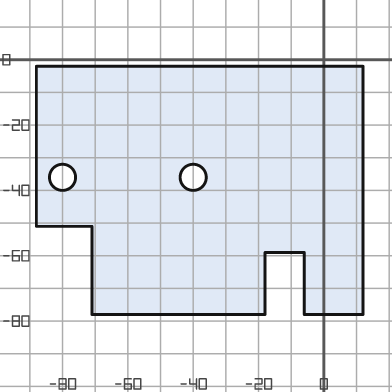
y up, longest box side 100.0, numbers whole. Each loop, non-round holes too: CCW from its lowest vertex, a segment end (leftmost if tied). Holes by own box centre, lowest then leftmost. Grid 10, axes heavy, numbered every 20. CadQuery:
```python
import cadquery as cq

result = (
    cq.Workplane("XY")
    .moveTo(-71.0, -78.0)
    .lineTo(-18.0, -78.0)
    .lineTo(-18.0, -59.0)
    .lineTo(-6.0, -59.0)
    .lineTo(-6.0, -78.0)
    .lineTo(12.0, -78.0)
    .lineTo(12.0, -2.0)
    .lineTo(-88.0, -2.0)
    .lineTo(-88.0, -51.0)
    .lineTo(-71.0, -51.0)
    .close()
    .moveTo(-80.0, -36.0)
    .circle(4.0)
    .moveTo(-40.0, -36.0)
    .circle(4.0)
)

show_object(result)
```